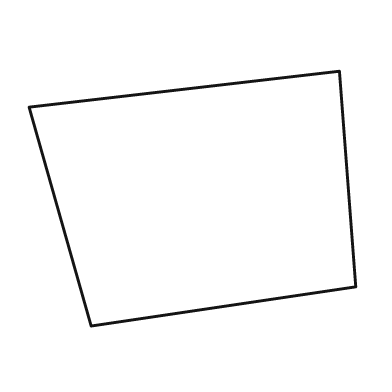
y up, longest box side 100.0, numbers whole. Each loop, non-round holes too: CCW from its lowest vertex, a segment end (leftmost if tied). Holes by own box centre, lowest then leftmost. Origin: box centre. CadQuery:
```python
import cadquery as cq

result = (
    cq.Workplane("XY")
    .moveTo(-31.0, -39.0)
    .lineTo(50.0, -27.0)
    .lineTo(45.0, 39.0)
    .lineTo(-50.0, 28.0)
    .close()
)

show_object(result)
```